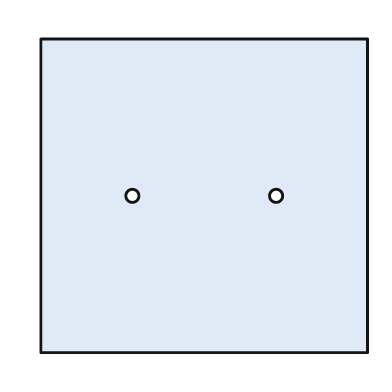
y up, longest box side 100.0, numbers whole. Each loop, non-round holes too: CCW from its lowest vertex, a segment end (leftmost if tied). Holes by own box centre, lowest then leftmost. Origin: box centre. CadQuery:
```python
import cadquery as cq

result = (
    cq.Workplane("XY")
    .moveTo(-50.0, -48.0)
    .lineTo(50.0, -48.0)
    .lineTo(50.0, 48.0)
    .lineTo(-50.0, 48.0)
    .close()
    .moveTo(-22.0, 0.0)
    .circle(2.0)
    .moveTo(22.0, 0.0)
    .circle(2.0)
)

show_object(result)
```